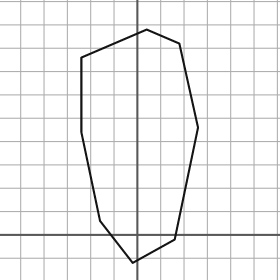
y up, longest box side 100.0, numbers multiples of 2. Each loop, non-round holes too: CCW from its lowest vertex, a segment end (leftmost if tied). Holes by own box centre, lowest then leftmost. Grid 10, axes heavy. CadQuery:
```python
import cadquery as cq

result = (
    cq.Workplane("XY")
    .moveTo(-2.0, -12.0)
    .lineTo(16.0, -2.0)
    .lineTo(26.0, 46.0)
    .lineTo(18.0, 82.0)
    .lineTo(4.0, 88.0)
    .lineTo(-24.0, 76.0)
    .lineTo(-24.0, 44.0)
    .lineTo(-16.0, 6.0)
    .close()
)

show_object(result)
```